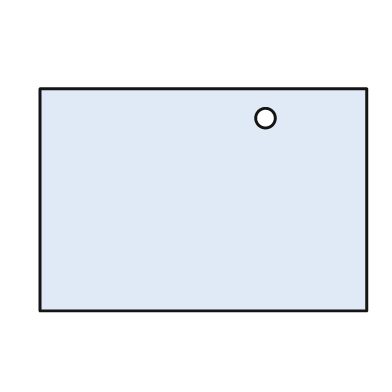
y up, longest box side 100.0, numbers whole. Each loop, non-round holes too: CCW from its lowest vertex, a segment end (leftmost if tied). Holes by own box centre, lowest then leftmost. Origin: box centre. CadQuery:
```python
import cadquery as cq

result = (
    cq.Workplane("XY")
    .moveTo(-50.0, -34.0)
    .lineTo(50.0, -34.0)
    .lineTo(50.0, 34.0)
    .lineTo(-50.0, 34.0)
    .close()
    .moveTo(19.0, 25.0)
    .circle(3.0)
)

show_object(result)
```